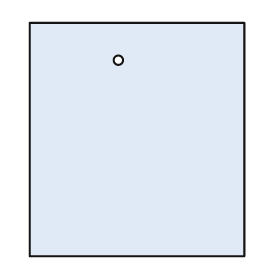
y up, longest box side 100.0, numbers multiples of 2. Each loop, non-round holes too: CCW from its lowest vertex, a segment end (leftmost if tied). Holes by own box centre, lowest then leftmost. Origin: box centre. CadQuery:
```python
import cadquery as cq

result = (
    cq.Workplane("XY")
    .moveTo(-46.0, -50.0)
    .lineTo(46.0, -50.0)
    .lineTo(46.0, 50.0)
    .lineTo(-46.0, 50.0)
    .close()
    .moveTo(-8.0, 34.0)
    .circle(2.0)
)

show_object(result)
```